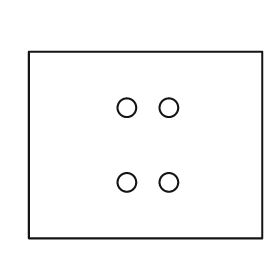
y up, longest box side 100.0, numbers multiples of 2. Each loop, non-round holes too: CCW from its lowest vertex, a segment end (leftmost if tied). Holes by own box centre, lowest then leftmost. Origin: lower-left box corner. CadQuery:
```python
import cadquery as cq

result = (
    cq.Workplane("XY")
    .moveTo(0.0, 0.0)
    .lineTo(100.0, 0.0)
    .lineTo(100.0, 80.0)
    .lineTo(0.0, 80.0)
    .close()
    .moveTo(42.0, 24.0)
    .circle(4.0)
    .moveTo(60.0, 24.0)
    .circle(4.0)
    .moveTo(42.0, 56.0)
    .circle(4.0)
    .moveTo(60.0, 56.0)
    .circle(4.0)
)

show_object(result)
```